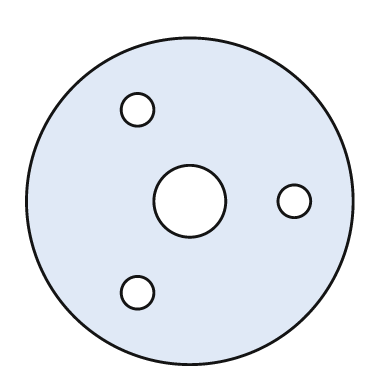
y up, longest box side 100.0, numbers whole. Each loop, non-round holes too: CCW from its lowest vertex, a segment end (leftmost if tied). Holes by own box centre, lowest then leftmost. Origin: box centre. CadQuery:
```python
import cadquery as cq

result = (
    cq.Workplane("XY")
    .moveTo(0.0, 0.0)
    .circle(50.0)
    .moveTo(-16.0, -28.0)
    .circle(5.0)
    .moveTo(0.0, 0.0)
    .circle(11.0)
    .moveTo(32.0, 0.0)
    .circle(5.0)
    .moveTo(-16.0, 28.0)
    .circle(5.0)
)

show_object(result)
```